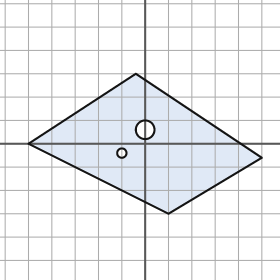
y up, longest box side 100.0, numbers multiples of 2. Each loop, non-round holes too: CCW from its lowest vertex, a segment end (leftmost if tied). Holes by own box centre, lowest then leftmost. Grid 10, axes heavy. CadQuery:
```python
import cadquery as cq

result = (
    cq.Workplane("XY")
    .moveTo(10.0, -30.0)
    .lineTo(50.0, -6.0)
    .lineTo(-4.0, 30.0)
    .lineTo(-50.0, 0.0)
    .close()
    .moveTo(-10.0, -4.0)
    .circle(2.0)
    .moveTo(0.0, 6.0)
    .circle(4.0)
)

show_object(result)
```